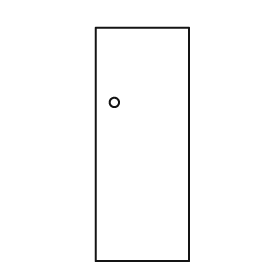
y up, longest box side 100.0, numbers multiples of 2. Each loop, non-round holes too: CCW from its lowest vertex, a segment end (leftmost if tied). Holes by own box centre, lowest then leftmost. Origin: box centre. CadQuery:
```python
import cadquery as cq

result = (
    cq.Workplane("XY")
    .moveTo(-20.0, -50.0)
    .lineTo(20.0, -50.0)
    .lineTo(20.0, 50.0)
    .lineTo(-20.0, 50.0)
    .close()
    .moveTo(-12.0, 18.0)
    .circle(2.0)
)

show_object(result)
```